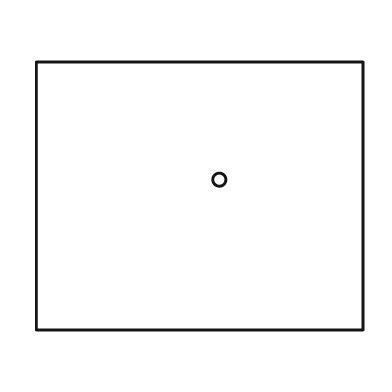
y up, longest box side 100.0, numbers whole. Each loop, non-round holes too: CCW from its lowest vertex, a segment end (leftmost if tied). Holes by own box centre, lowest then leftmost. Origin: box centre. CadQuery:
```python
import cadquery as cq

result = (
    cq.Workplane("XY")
    .moveTo(-50.0, -41.0)
    .lineTo(50.0, -41.0)
    .lineTo(50.0, 41.0)
    .lineTo(-50.0, 41.0)
    .close()
    .moveTo(6.0, 5.0)
    .circle(2.0)
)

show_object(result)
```